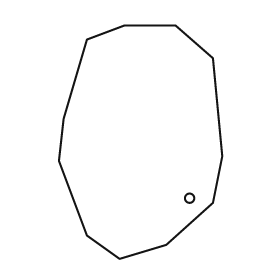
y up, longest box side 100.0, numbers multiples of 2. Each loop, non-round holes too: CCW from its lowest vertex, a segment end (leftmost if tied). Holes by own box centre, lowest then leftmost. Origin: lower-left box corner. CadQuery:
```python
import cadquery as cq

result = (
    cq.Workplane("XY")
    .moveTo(26.0, 0.0)
    .lineTo(46.0, 6.0)
    .lineTo(66.0, 24.0)
    .lineTo(70.0, 44.0)
    .lineTo(66.0, 86.0)
    .lineTo(50.0, 100.0)
    .lineTo(28.0, 100.0)
    .lineTo(12.0, 94.0)
    .lineTo(2.0, 60.0)
    .lineTo(0.0, 42.0)
    .lineTo(12.0, 10.0)
    .close()
    .moveTo(56.0, 26.0)
    .circle(2.0)
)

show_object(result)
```